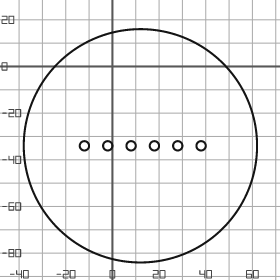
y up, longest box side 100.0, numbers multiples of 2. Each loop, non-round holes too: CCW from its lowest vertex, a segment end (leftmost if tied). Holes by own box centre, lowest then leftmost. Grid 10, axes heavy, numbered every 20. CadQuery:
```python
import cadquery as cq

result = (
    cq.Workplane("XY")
    .moveTo(12.0, -34.0)
    .circle(50.0)
    .moveTo(-12.0, -34.0)
    .circle(2.0)
    .moveTo(-2.0, -34.0)
    .circle(2.0)
    .moveTo(8.0, -34.0)
    .circle(2.0)
    .moveTo(18.0, -34.0)
    .circle(2.0)
    .moveTo(28.0, -34.0)
    .circle(2.0)
    .moveTo(38.0, -34.0)
    .circle(2.0)
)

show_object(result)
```